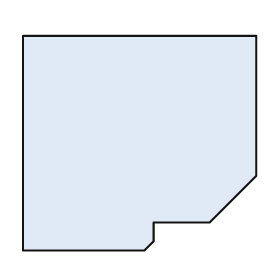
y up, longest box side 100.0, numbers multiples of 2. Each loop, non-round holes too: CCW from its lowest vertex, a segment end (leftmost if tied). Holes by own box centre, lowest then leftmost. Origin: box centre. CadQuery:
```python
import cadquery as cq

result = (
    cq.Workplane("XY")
    .moveTo(-50.0, -46.0)
    .lineTo(2.0, -46.0)
    .lineTo(6.0, -42.0)
    .lineTo(6.0, -34.0)
    .lineTo(30.0, -34.0)
    .lineTo(50.0, -14.0)
    .lineTo(50.0, 46.0)
    .lineTo(-50.0, 46.0)
    .close()
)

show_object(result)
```